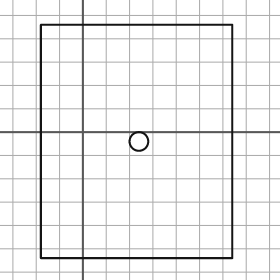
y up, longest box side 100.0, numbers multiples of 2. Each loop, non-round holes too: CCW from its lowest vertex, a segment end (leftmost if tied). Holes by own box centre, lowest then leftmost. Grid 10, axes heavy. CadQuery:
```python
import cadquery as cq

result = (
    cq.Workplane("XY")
    .moveTo(-18.0, -54.0)
    .lineTo(64.0, -54.0)
    .lineTo(64.0, 46.0)
    .lineTo(-18.0, 46.0)
    .close()
    .moveTo(24.0, -4.0)
    .circle(4.0)
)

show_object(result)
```